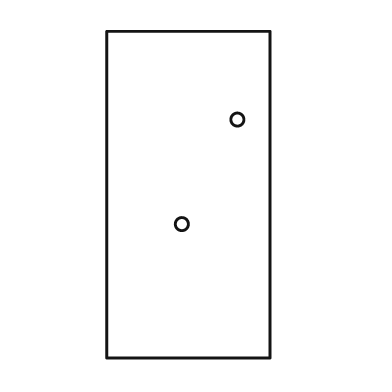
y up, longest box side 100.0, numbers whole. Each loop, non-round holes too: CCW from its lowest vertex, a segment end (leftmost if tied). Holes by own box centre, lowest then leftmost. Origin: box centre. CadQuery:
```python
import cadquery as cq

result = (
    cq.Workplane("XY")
    .moveTo(-25.0, -50.0)
    .lineTo(25.0, -50.0)
    .lineTo(25.0, 50.0)
    .lineTo(-25.0, 50.0)
    .close()
    .moveTo(-2.0, -9.0)
    .circle(2.0)
    .moveTo(15.0, 23.0)
    .circle(2.0)
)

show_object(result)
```